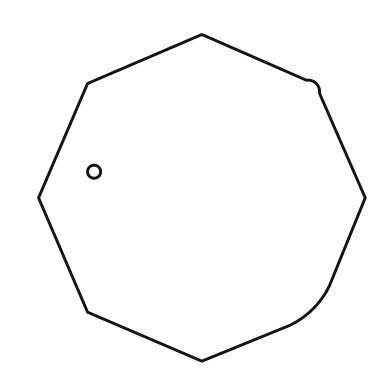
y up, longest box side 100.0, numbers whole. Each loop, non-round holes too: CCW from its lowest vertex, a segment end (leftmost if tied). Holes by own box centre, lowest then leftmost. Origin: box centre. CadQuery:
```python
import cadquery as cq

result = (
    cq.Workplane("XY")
    .moveTo(0.0, -50.0)
    .lineTo(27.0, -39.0)
    .threePointArc((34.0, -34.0), (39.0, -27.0))
    .lineTo(50.0, 0.0)
    .lineTo(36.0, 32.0)
    .threePointArc((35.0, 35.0), (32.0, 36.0))
    .lineTo(0.0, 50.0)
    .lineTo(-35.0, 35.0)
    .lineTo(-50.0, 0.0)
    .lineTo(-35.0, -35.0)
    .close()
    .moveTo(-33.0, 8.0)
    .circle(2.0)
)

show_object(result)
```